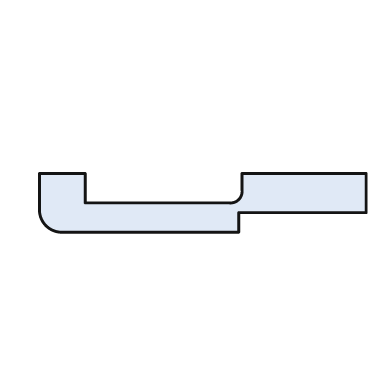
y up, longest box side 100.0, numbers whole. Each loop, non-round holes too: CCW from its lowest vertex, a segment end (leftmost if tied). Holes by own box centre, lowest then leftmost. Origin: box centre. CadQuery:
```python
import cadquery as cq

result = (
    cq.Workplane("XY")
    .moveTo(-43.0, -9.0)
    .lineTo(11.0, -9.0)
    .lineTo(11.0, -3.0)
    .lineTo(50.0, -3.0)
    .lineTo(50.0, 9.0)
    .lineTo(12.0, 9.0)
    .lineTo(12.0, 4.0)
    .threePointArc((11.0, 1.0), (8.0, 0.0))
    .lineTo(-36.0, 0.0)
    .lineTo(-36.0, 9.0)
    .lineTo(-50.0, 9.0)
    .lineTo(-50.0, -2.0)
    .threePointArc((-48.0, -7.0), (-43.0, -9.0))
    .close()
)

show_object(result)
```